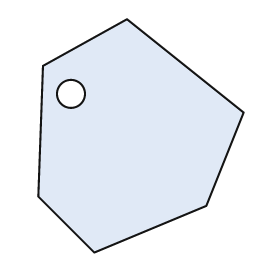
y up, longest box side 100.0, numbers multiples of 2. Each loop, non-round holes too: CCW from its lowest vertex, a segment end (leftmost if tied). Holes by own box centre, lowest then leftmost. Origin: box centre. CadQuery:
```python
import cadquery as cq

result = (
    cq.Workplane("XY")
    .moveTo(-20.0, -50.0)
    .lineTo(28.0, -30.0)
    .lineTo(44.0, 10.0)
    .lineTo(-6.0, 50.0)
    .lineTo(-42.0, 30.0)
    .lineTo(-44.0, -26.0)
    .close()
    .moveTo(-30.0, 18.0)
    .circle(6.0)
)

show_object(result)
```